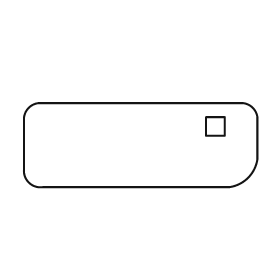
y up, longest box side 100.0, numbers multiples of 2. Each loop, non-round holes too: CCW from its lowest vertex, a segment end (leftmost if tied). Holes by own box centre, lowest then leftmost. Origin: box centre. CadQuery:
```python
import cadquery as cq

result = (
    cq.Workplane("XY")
    .moveTo(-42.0, -18.0)
    .lineTo(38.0, -18.0)
    .threePointArc((46.0, -14.0), (50.0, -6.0))
    .lineTo(50.0, 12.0)
    .threePointArc((48.0, 16.0), (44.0, 18.0))
    .lineTo(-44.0, 18.0)
    .threePointArc((-48.0, 16.0), (-50.0, 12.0))
    .lineTo(-50.0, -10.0)
    .threePointArc((-48.0, -16.0), (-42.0, -18.0))
    .close()
    .moveTo(28.0, 4.0)
    .lineTo(36.0, 4.0)
    .lineTo(36.0, 12.0)
    .lineTo(28.0, 12.0)
    .close()
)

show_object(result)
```